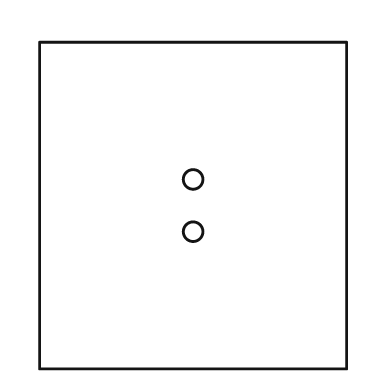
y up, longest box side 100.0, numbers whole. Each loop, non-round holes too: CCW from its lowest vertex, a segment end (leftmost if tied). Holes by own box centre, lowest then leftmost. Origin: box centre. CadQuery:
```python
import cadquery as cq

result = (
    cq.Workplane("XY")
    .moveTo(-47.0, -50.0)
    .lineTo(47.0, -50.0)
    .lineTo(47.0, 50.0)
    .lineTo(-47.0, 50.0)
    .close()
    .moveTo(0.0, -8.0)
    .circle(3.0)
    .moveTo(0.0, 8.0)
    .circle(3.0)
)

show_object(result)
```